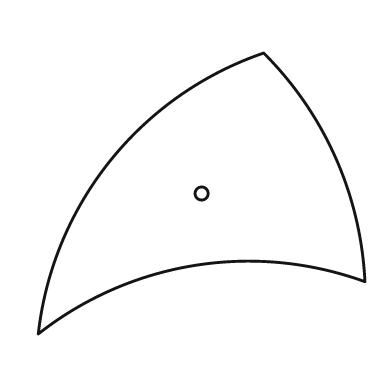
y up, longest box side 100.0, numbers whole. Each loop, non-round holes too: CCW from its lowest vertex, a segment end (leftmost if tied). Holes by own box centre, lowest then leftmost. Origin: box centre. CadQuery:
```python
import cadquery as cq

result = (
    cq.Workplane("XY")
    .moveTo(-50.0, -43.0)
    .threePointArc((-2.0, -22.0), (50.0, -27.0))
    .threePointArc((41.0, 11.0), (19.0, 43.0))
    .threePointArc((-28.0, 10.0), (-50.0, -43.0))
    .close()
    .moveTo(0.0, 0.0)
    .circle(2.0)
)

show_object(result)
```